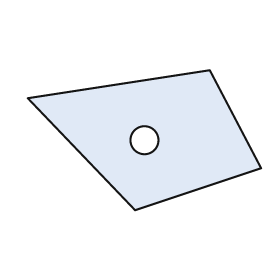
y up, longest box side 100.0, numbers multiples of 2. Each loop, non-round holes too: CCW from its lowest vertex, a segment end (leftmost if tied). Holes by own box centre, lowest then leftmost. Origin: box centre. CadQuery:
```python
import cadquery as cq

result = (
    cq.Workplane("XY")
    .moveTo(-4.0, -30.0)
    .lineTo(50.0, -12.0)
    .lineTo(28.0, 30.0)
    .lineTo(-50.0, 18.0)
    .close()
    .moveTo(0.0, 0.0)
    .circle(6.0)
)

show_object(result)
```